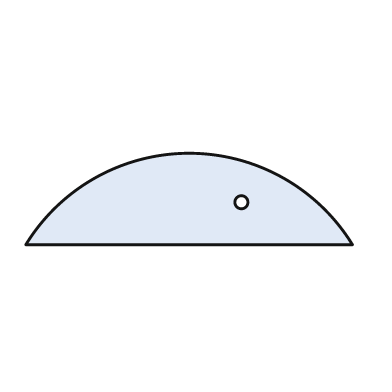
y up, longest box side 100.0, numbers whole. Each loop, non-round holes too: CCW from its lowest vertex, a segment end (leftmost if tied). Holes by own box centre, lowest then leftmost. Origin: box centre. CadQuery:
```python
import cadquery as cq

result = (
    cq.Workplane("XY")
    .moveTo(-50.0, -14.0)
    .lineTo(50.0, -14.0)
    .threePointArc((0.0, 14.0), (-50.0, -14.0))
    .close()
    .moveTo(16.0, -1.0)
    .circle(2.0)
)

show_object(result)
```